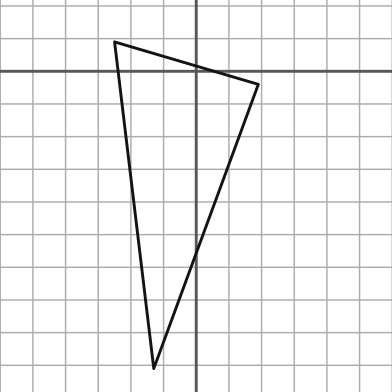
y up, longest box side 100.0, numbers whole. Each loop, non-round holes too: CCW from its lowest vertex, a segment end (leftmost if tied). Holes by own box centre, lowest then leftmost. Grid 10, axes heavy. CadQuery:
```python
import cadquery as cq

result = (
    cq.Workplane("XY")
    .moveTo(-13.0, -91.0)
    .lineTo(19.0, -4.0)
    .lineTo(-25.0, 9.0)
    .close()
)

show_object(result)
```